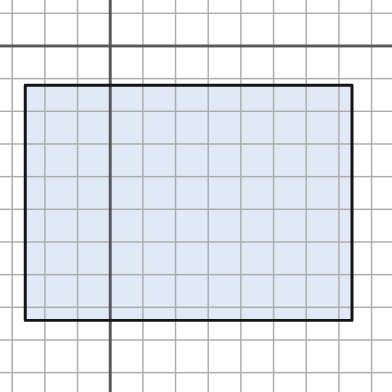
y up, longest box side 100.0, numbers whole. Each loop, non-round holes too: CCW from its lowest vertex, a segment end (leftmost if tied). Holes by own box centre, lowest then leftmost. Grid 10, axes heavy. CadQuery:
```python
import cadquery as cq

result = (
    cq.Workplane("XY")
    .moveTo(-26.0, -84.0)
    .lineTo(74.0, -84.0)
    .lineTo(74.0, -12.0)
    .lineTo(-26.0, -12.0)
    .close()
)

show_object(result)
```